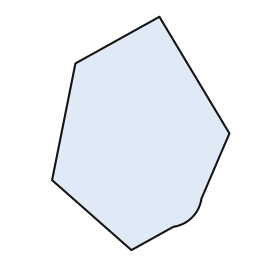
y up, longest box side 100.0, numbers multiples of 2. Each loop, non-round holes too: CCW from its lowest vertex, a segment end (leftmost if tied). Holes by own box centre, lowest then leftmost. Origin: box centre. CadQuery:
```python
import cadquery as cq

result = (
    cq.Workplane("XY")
    .moveTo(-4.0, -50.0)
    .lineTo(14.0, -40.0)
    .threePointArc((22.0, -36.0), (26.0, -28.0))
    .lineTo(38.0, 0.0)
    .lineTo(8.0, 50.0)
    .lineTo(-28.0, 30.0)
    .lineTo(-38.0, -20.0)
    .close()
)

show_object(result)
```